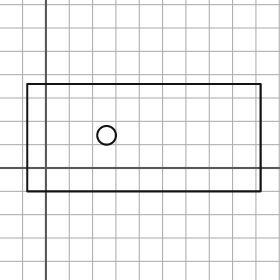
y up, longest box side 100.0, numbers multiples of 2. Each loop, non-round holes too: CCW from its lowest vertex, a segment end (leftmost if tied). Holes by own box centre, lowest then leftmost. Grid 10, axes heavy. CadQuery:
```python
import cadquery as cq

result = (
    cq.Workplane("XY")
    .moveTo(-8.0, -10.0)
    .lineTo(92.0, -10.0)
    .lineTo(92.0, 36.0)
    .lineTo(-8.0, 36.0)
    .close()
    .moveTo(26.0, 14.0)
    .circle(4.0)
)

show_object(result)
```